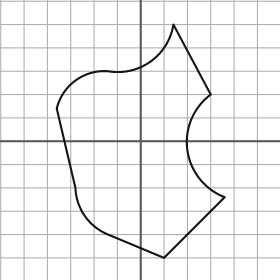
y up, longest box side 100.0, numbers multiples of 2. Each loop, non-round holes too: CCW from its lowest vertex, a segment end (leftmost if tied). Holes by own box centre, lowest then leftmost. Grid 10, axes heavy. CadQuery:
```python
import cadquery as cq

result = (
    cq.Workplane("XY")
    .moveTo(10.0, -50.0)
    .lineTo(36.0, -24.0)
    .threePointArc((20.0, -4.0), (30.0, 20.0))
    .lineTo(14.0, 50.0)
    .threePointArc((4.0, 34.0), (-14.0, 30.0))
    .threePointArc((-28.0, 26.0), (-36.0, 14.0))
    .lineTo(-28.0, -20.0)
    .threePointArc((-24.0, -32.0), (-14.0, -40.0))
    .close()
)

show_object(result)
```